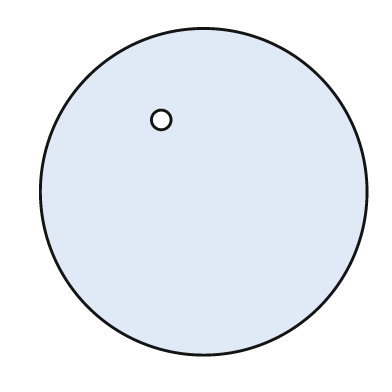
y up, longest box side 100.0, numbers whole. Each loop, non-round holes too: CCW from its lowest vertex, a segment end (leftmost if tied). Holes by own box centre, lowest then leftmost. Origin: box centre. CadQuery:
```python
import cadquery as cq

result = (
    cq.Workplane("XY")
    .moveTo(0.0, 0.0)
    .circle(50.0)
    .moveTo(-13.0, 22.0)
    .circle(3.0)
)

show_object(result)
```